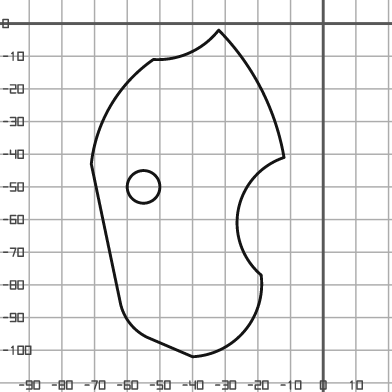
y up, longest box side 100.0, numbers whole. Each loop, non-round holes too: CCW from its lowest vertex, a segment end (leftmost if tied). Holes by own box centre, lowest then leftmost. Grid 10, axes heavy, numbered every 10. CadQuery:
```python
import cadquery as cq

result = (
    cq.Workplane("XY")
    .moveTo(-40.0, -102.0)
    .threePointArc((-24.0, -94.0), (-19.0, -77.0))
    .threePointArc((-26.0, -57.0), (-12.0, -41.0))
    .threePointArc((-19.0, -20.0), (-32.0, -2.0))
    .threePointArc((-41.0, -9.0), (-52.0, -11.0))
    .threePointArc((-65.0, -25.0), (-71.0, -43.0))
    .lineTo(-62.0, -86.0)
    .threePointArc((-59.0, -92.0), (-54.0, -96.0))
    .close()
    .moveTo(-55.0, -50.0)
    .circle(5.0)
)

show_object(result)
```